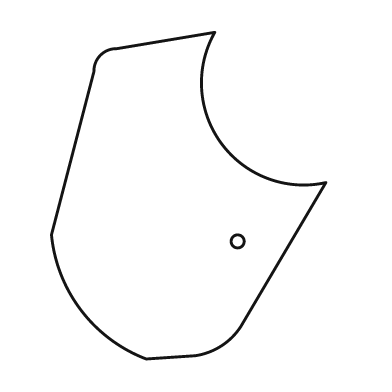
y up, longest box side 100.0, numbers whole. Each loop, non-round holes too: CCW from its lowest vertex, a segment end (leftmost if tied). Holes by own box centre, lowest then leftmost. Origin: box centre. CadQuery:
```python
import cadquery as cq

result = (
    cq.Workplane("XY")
    .moveTo(-13.0, -50.0)
    .lineTo(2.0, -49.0)
    .threePointArc((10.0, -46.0), (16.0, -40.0))
    .lineTo(42.0, 4.0)
    .threePointArc((10.0, 16.0), (8.0, 50.0))
    .lineTo(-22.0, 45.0)
    .threePointArc((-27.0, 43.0), (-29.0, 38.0))
    .lineTo(-42.0, -12.0)
    .threePointArc((-33.0, -35.0), (-13.0, -50.0))
    .close()
    .moveTo(15.0, -14.0)
    .circle(2.0)
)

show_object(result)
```